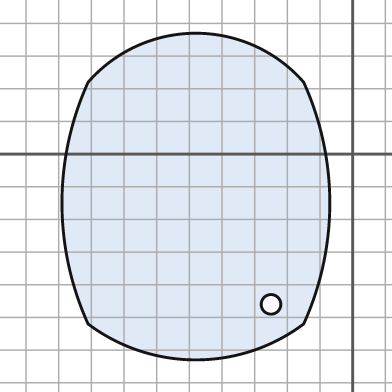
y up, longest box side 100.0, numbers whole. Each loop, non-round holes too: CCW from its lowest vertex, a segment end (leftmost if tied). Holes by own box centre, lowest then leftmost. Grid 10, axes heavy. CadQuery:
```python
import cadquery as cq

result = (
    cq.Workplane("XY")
    .moveTo(-81.0, -52.0)
    .threePointArc((-48.0, -63.0), (-15.0, -52.0))
    .threePointArc((-7.0, -15.0), (-15.0, 22.0))
    .threePointArc((-48.0, 37.0), (-81.0, 22.0))
    .threePointArc((-89.0, -15.0), (-81.0, -52.0))
    .close()
    .moveTo(-25.0, -46.0)
    .circle(3.0)
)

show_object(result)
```